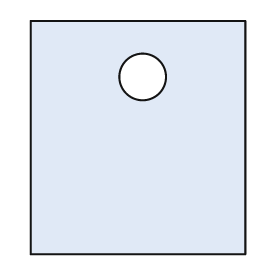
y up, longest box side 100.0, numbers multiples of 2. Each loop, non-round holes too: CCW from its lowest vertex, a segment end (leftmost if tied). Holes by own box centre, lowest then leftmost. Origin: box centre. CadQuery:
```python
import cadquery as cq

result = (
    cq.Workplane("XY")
    .moveTo(-46.0, -50.0)
    .lineTo(46.0, -50.0)
    .lineTo(46.0, 50.0)
    .lineTo(-46.0, 50.0)
    .close()
    .moveTo(2.0, 26.0)
    .circle(10.0)
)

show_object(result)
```